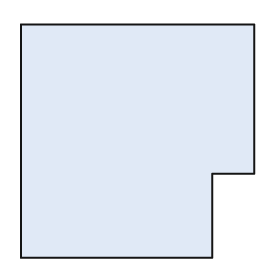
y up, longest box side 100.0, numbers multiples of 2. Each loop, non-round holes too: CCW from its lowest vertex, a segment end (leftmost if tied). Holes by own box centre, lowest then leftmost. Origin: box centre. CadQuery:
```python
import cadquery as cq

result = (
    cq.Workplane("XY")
    .moveTo(-50.0, -50.0)
    .lineTo(32.0, -50.0)
    .lineTo(32.0, -14.0)
    .lineTo(50.0, -14.0)
    .lineTo(50.0, 50.0)
    .lineTo(-50.0, 50.0)
    .close()
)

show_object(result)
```